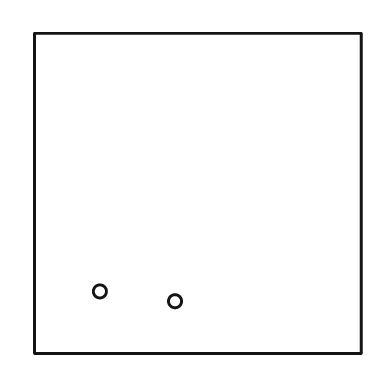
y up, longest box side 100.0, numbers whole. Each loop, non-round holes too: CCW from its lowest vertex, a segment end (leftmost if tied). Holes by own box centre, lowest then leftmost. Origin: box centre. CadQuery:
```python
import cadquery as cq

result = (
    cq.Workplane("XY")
    .moveTo(-50.0, -49.0)
    .lineTo(50.0, -49.0)
    .lineTo(50.0, 49.0)
    .lineTo(-50.0, 49.0)
    .close()
    .moveTo(-7.0, -33.0)
    .circle(2.0)
    .moveTo(-30.0, -30.0)
    .circle(2.0)
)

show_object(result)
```